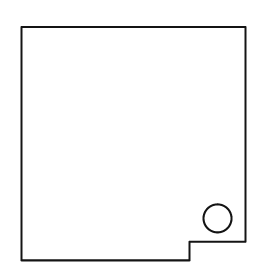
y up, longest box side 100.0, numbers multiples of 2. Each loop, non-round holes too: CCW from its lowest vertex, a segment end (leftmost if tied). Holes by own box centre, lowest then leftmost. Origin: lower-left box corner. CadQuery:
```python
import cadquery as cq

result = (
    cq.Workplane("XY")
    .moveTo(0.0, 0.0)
    .lineTo(72.0, 0.0)
    .lineTo(72.0, 8.0)
    .lineTo(96.0, 8.0)
    .lineTo(96.0, 100.0)
    .lineTo(0.0, 100.0)
    .close()
    .moveTo(84.0, 18.0)
    .circle(6.0)
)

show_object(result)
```